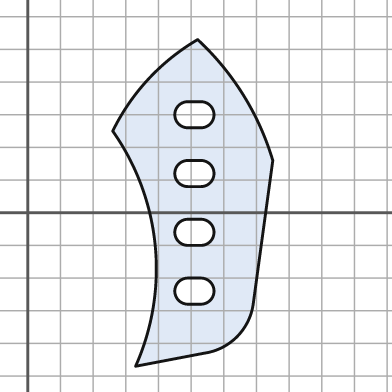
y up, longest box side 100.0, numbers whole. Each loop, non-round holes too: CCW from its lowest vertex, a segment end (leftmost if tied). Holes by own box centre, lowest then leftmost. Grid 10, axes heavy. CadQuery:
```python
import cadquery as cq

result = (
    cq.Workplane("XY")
    .moveTo(33.0, -47.0)
    .lineTo(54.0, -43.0)
    .threePointArc((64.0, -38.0), (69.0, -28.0))
    .lineTo(75.0, 16.0)
    .threePointArc((66.0, 36.0), (52.0, 53.0))
    .threePointArc((37.0, 41.0), (26.0, 25.0))
    .threePointArc((39.0, -10.0), (33.0, -47.0))
    .close()
    .moveTo(49.0, -28.0)
    .lineTo(53.0, -28.0)
    .threePointArc((57.0, -24.0), (53.0, -20.0))
    .lineTo(49.0, -20.0)
    .threePointArc((45.0, -24.0), (49.0, -28.0))
    .close()
    .moveTo(49.0, -10.0)
    .lineTo(53.0, -10.0)
    .threePointArc((57.0, -6.0), (53.0, -2.0))
    .lineTo(49.0, -2.0)
    .threePointArc((45.0, -6.0), (49.0, -10.0))
    .close()
    .moveTo(49.0, 8.0)
    .lineTo(53.0, 8.0)
    .threePointArc((57.0, 12.0), (53.0, 16.0))
    .lineTo(49.0, 16.0)
    .threePointArc((45.0, 12.0), (49.0, 8.0))
    .close()
    .moveTo(49.0, 26.0)
    .lineTo(53.0, 26.0)
    .threePointArc((57.0, 30.0), (53.0, 34.0))
    .lineTo(49.0, 34.0)
    .threePointArc((45.0, 30.0), (49.0, 26.0))
    .close()
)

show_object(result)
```